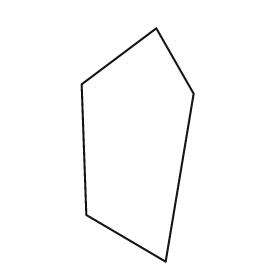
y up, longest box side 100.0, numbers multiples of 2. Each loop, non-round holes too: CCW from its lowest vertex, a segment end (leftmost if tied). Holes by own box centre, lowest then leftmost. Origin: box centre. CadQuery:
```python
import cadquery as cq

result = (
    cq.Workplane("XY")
    .moveTo(12.0, -50.0)
    .lineTo(24.0, 22.0)
    .lineTo(8.0, 50.0)
    .lineTo(-24.0, 26.0)
    .lineTo(-22.0, -30.0)
    .close()
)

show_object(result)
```